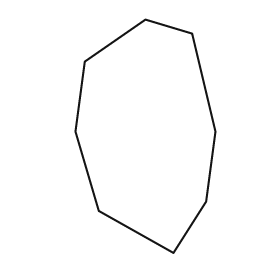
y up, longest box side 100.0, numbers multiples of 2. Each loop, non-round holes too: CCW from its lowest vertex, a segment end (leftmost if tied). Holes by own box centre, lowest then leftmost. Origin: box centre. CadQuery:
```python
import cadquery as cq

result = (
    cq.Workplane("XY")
    .moveTo(12.0, -50.0)
    .lineTo(26.0, -28.0)
    .lineTo(30.0, 2.0)
    .lineTo(20.0, 44.0)
    .lineTo(0.0, 50.0)
    .lineTo(-26.0, 32.0)
    .lineTo(-30.0, 2.0)
    .lineTo(-20.0, -32.0)
    .close()
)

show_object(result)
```